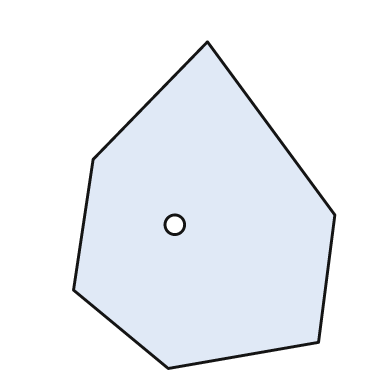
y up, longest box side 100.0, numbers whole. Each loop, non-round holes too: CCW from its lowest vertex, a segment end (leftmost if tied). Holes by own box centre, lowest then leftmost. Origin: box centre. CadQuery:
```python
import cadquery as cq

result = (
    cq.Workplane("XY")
    .moveTo(-11.0, -50.0)
    .lineTo(35.0, -42.0)
    .lineTo(40.0, -3.0)
    .lineTo(1.0, 50.0)
    .lineTo(-34.0, 14.0)
    .lineTo(-40.0, -26.0)
    .close()
    .moveTo(-9.0, -6.0)
    .circle(3.0)
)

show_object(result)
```